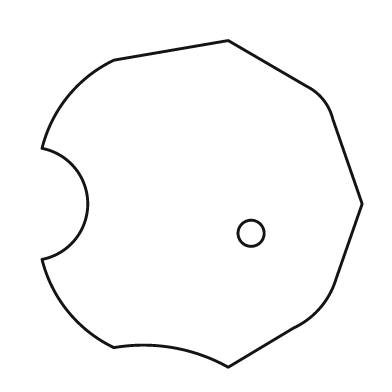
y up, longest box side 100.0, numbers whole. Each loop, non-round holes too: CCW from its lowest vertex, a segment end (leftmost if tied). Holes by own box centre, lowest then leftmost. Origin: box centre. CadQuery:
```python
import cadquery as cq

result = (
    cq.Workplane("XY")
    .moveTo(8.0, -50.0)
    .lineTo(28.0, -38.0)
    .threePointArc((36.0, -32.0), (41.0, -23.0))
    .lineTo(49.0, 0.0)
    .lineTo(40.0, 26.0)
    .threePointArc((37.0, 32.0), (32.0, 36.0))
    .lineTo(8.0, 50.0)
    .lineTo(-27.0, 44.0)
    .threePointArc((-41.0, 33.0), (-49.0, 17.0))
    .threePointArc((-35.0, 0.0), (-49.0, -17.0))
    .threePointArc((-41.0, -33.0), (-27.0, -44.0))
    .threePointArc((-9.0, -44.0), (8.0, -50.0))
    .close()
    .moveTo(15.0, -9.0)
    .circle(4.0)
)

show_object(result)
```